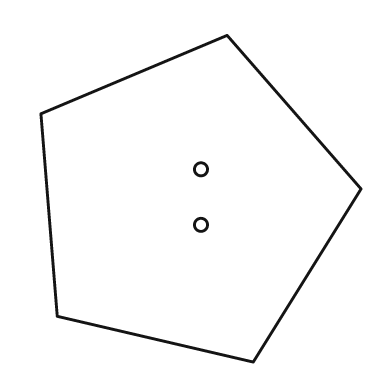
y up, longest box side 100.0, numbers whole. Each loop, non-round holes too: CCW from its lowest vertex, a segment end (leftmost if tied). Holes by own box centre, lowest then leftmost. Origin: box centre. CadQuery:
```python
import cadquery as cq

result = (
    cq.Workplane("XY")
    .moveTo(16.0, -50.0)
    .lineTo(49.0, 3.0)
    .lineTo(8.0, 50.0)
    .lineTo(-49.0, 26.0)
    .lineTo(-44.0, -36.0)
    .close()
    .moveTo(0.0, -8.0)
    .circle(2.0)
    .moveTo(0.0, 9.0)
    .circle(2.0)
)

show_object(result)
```